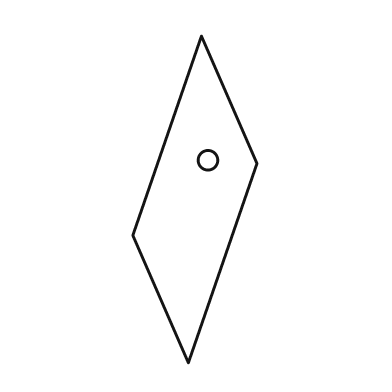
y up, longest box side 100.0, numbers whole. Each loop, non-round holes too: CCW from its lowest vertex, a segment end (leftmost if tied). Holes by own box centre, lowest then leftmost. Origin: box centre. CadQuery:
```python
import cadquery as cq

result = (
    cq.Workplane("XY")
    .moveTo(-2.0, -50.0)
    .lineTo(19.0, 11.0)
    .lineTo(2.0, 50.0)
    .lineTo(-19.0, -11.0)
    .close()
    .moveTo(4.0, 12.0)
    .circle(3.0)
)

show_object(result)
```